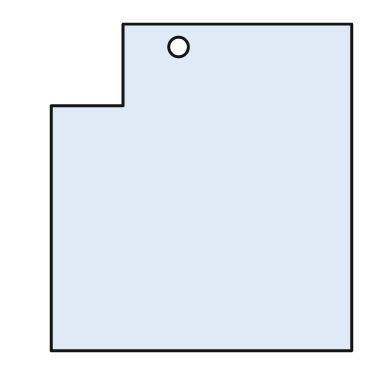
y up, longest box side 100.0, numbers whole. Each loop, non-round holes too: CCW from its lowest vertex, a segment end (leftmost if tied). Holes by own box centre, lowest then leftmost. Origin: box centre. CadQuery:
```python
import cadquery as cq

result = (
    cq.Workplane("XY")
    .moveTo(-46.0, -50.0)
    .lineTo(46.0, -50.0)
    .lineTo(46.0, 50.0)
    .lineTo(-24.0, 50.0)
    .lineTo(-24.0, 25.0)
    .lineTo(-46.0, 25.0)
    .close()
    .moveTo(-7.0, 43.0)
    .circle(3.0)
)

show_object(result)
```